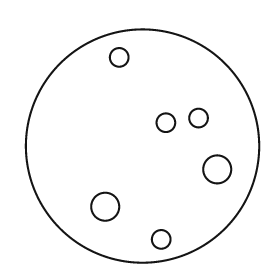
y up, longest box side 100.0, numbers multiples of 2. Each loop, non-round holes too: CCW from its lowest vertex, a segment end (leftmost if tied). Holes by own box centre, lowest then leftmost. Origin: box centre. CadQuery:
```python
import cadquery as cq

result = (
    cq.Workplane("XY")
    .moveTo(0.0, 0.0)
    .circle(50.0)
    .moveTo(8.0, -40.0)
    .circle(4.0)
    .moveTo(-16.0, -26.0)
    .circle(6.0)
    .moveTo(32.0, -10.0)
    .circle(6.0)
    .moveTo(10.0, 10.0)
    .circle(4.0)
    .moveTo(24.0, 12.0)
    .circle(4.0)
    .moveTo(-10.0, 38.0)
    .circle(4.0)
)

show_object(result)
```